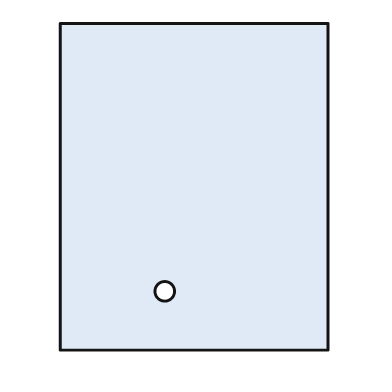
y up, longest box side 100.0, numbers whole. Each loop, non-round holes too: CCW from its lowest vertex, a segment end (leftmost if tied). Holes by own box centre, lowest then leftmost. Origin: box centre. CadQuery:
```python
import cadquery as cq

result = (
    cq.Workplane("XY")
    .moveTo(-41.0, -50.0)
    .lineTo(41.0, -50.0)
    .lineTo(41.0, 50.0)
    .lineTo(-41.0, 50.0)
    .close()
    .moveTo(-9.0, -32.0)
    .circle(3.0)
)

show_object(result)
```